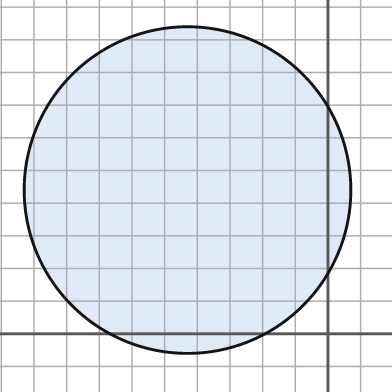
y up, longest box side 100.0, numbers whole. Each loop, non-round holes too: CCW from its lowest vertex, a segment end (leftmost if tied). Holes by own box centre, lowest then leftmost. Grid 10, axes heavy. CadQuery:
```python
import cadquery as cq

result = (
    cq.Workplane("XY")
    .moveTo(-43.0, 44.0)
    .circle(50.0)
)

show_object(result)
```